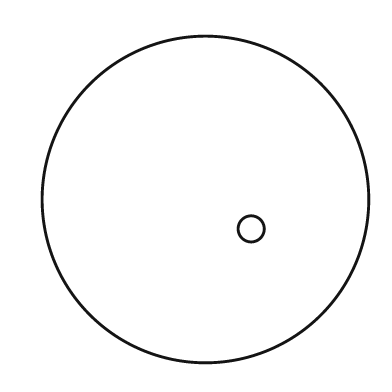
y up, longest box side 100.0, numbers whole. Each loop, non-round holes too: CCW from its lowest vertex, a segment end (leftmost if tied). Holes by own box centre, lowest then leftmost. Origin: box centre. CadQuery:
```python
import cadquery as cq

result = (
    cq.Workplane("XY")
    .moveTo(0.0, 0.0)
    .circle(50.0)
    .moveTo(14.0, -9.0)
    .circle(4.0)
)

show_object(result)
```